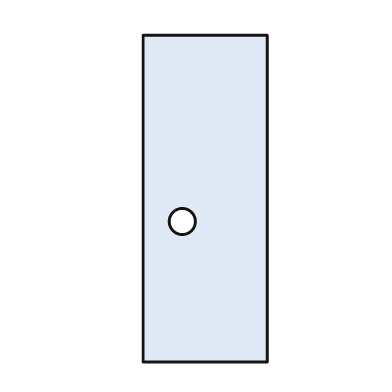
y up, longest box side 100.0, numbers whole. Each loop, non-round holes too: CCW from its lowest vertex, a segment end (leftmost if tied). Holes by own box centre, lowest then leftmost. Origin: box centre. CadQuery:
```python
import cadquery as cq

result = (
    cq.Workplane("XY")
    .moveTo(-19.0, -50.0)
    .lineTo(19.0, -50.0)
    .lineTo(19.0, 50.0)
    .lineTo(-19.0, 50.0)
    .close()
    .moveTo(-7.0, -7.0)
    .circle(4.0)
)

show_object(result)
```